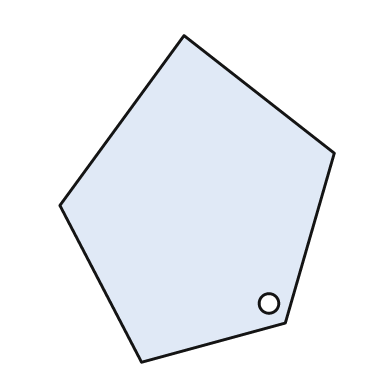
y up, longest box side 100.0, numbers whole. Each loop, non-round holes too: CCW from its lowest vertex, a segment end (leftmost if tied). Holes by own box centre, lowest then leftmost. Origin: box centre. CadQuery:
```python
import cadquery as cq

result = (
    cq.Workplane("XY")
    .moveTo(-17.0, -50.0)
    .lineTo(27.0, -38.0)
    .lineTo(42.0, 14.0)
    .lineTo(-4.0, 50.0)
    .lineTo(-42.0, -2.0)
    .close()
    .moveTo(22.0, -32.0)
    .circle(3.0)
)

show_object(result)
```